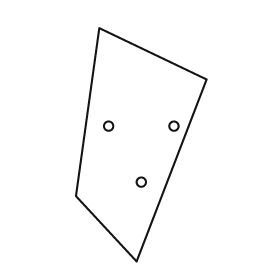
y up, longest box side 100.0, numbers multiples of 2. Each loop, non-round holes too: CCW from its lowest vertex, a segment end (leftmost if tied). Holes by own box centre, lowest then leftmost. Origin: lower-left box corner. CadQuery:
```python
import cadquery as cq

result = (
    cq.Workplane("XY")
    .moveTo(26.0, 0.0)
    .lineTo(56.0, 78.0)
    .lineTo(10.0, 100.0)
    .lineTo(0.0, 28.0)
    .close()
    .moveTo(28.0, 34.0)
    .circle(2.0)
    .moveTo(14.0, 58.0)
    .circle(2.0)
    .moveTo(42.0, 58.0)
    .circle(2.0)
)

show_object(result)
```